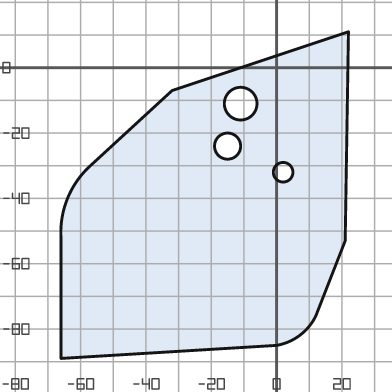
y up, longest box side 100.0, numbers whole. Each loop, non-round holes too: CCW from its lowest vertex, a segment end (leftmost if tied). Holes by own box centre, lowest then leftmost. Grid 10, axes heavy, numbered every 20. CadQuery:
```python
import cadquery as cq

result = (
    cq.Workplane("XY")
    .moveTo(-66.0, -89.0)
    .lineTo(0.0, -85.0)
    .threePointArc((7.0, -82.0), (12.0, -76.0))
    .lineTo(21.0, -53.0)
    .lineTo(22.0, 11.0)
    .lineTo(-32.0, -7.0)
    .lineTo(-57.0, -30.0)
    .threePointArc((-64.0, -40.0), (-66.0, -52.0))
    .close()
    .moveTo(2.0, -32.0)
    .circle(3.0)
    .moveTo(-15.0, -24.0)
    .circle(4.0)
    .moveTo(-11.0, -11.0)
    .circle(5.0)
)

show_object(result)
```